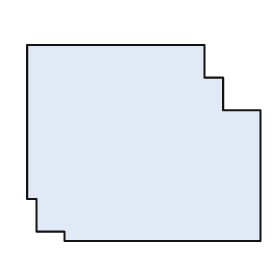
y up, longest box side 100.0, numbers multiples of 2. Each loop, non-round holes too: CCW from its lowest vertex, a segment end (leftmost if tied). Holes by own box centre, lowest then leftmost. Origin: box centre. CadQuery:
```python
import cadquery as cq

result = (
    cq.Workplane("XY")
    .moveTo(-34.0, -42.0)
    .lineTo(50.0, -42.0)
    .lineTo(50.0, 14.0)
    .lineTo(34.0, 14.0)
    .lineTo(34.0, 28.0)
    .lineTo(26.0, 28.0)
    .lineTo(26.0, 42.0)
    .lineTo(-50.0, 42.0)
    .lineTo(-50.0, -24.0)
    .lineTo(-46.0, -24.0)
    .lineTo(-46.0, -38.0)
    .lineTo(-34.0, -38.0)
    .close()
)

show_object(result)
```